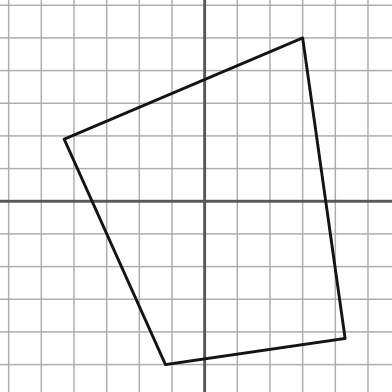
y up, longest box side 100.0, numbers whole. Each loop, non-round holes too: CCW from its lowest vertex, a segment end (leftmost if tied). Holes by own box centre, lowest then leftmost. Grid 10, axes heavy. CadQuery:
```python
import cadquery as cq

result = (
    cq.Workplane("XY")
    .moveTo(-12.0, -50.0)
    .lineTo(43.0, -42.0)
    .lineTo(30.0, 50.0)
    .lineTo(-43.0, 19.0)
    .close()
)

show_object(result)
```